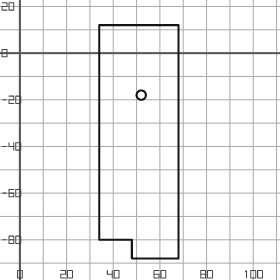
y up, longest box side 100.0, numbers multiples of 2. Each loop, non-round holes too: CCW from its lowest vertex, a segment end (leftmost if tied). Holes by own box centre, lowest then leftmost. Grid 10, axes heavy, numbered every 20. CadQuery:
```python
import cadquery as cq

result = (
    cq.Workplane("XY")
    .moveTo(48.0, -88.0)
    .lineTo(68.0, -88.0)
    .lineTo(68.0, 12.0)
    .lineTo(34.0, 12.0)
    .lineTo(34.0, -80.0)
    .lineTo(48.0, -80.0)
    .close()
    .moveTo(52.0, -18.0)
    .circle(2.0)
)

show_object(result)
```